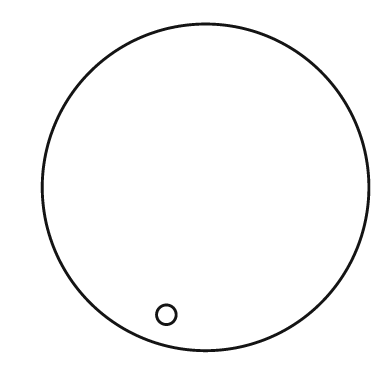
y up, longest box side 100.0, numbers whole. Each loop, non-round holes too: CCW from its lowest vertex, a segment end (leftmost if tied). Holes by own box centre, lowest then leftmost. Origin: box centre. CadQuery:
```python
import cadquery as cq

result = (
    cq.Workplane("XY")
    .moveTo(0.0, 0.0)
    .circle(50.0)
    .moveTo(-12.0, -39.0)
    .circle(3.0)
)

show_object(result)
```